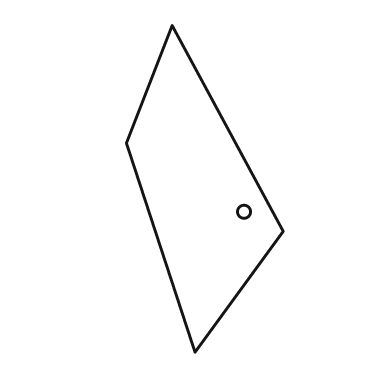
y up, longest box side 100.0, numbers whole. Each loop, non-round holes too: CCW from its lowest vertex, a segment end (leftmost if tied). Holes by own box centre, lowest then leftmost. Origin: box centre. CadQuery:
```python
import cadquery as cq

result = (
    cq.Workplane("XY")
    .moveTo(-3.0, -50.0)
    .lineTo(24.0, -13.0)
    .lineTo(-10.0, 50.0)
    .lineTo(-24.0, 14.0)
    .close()
    .moveTo(12.0, -7.0)
    .circle(2.0)
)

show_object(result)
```